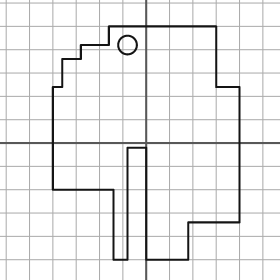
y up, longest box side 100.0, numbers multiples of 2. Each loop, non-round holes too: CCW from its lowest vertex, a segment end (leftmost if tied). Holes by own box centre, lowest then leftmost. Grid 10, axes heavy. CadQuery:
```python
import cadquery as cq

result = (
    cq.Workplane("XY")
    .moveTo(-14.0, -50.0)
    .lineTo(-8.0, -50.0)
    .lineTo(-8.0, -2.0)
    .lineTo(0.0, -2.0)
    .lineTo(0.0, -50.0)
    .lineTo(18.0, -50.0)
    .lineTo(18.0, -34.0)
    .lineTo(40.0, -34.0)
    .lineTo(40.0, 24.0)
    .lineTo(30.0, 24.0)
    .lineTo(30.0, 50.0)
    .lineTo(-16.0, 50.0)
    .lineTo(-16.0, 42.0)
    .lineTo(-28.0, 42.0)
    .lineTo(-28.0, 36.0)
    .lineTo(-36.0, 36.0)
    .lineTo(-36.0, 24.0)
    .lineTo(-40.0, 24.0)
    .lineTo(-40.0, -20.0)
    .lineTo(-14.0, -20.0)
    .close()
    .moveTo(-8.0, 42.0)
    .circle(4.0)
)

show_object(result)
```